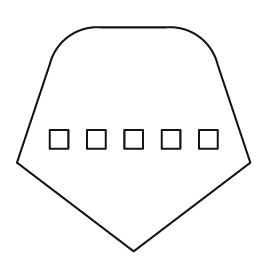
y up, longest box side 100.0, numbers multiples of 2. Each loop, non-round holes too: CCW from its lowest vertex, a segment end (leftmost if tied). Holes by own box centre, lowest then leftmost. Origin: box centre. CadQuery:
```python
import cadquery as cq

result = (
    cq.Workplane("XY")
    .moveTo(0.0, -48.0)
    .lineTo(50.0, -10.0)
    .lineTo(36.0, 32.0)
    .threePointArc((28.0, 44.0), (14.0, 48.0))
    .lineTo(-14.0, 48.0)
    .threePointArc((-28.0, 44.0), (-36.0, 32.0))
    .lineTo(-50.0, -10.0)
    .close()
    .moveTo(-36.0, -4.0)
    .lineTo(-28.0, -4.0)
    .lineTo(-28.0, 4.0)
    .lineTo(-36.0, 4.0)
    .close()
    .moveTo(-20.0, -4.0)
    .lineTo(-12.0, -4.0)
    .lineTo(-12.0, 4.0)
    .lineTo(-20.0, 4.0)
    .close()
    .moveTo(-4.0, -4.0)
    .lineTo(4.0, -4.0)
    .lineTo(4.0, 4.0)
    .lineTo(-4.0, 4.0)
    .close()
    .moveTo(12.0, -4.0)
    .lineTo(20.0, -4.0)
    .lineTo(20.0, 4.0)
    .lineTo(12.0, 4.0)
    .close()
    .moveTo(28.0, -4.0)
    .lineTo(36.0, -4.0)
    .lineTo(36.0, 4.0)
    .lineTo(28.0, 4.0)
    .close()
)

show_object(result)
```